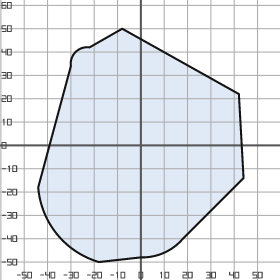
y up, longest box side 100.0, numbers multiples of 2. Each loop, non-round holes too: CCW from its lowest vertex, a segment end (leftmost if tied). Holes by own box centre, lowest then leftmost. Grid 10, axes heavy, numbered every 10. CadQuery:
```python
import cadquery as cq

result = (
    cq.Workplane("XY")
    .moveTo(-18.0, -50.0)
    .lineTo(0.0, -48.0)
    .threePointArc((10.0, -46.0), (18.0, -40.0))
    .lineTo(44.0, -14.0)
    .lineTo(42.0, 22.0)
    .lineTo(-8.0, 50.0)
    .lineTo(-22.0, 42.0)
    .threePointArc((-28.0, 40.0), (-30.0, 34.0))
    .lineTo(-44.0, -18.0)
    .threePointArc((-36.0, -38.0), (-18.0, -50.0))
    .close()
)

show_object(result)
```